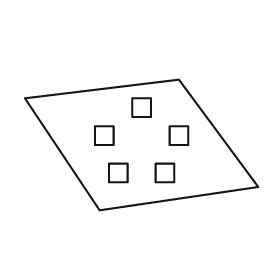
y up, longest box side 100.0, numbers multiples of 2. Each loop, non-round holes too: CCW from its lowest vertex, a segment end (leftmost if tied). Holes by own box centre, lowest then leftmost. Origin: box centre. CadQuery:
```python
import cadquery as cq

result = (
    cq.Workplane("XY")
    .moveTo(-18.0, -28.0)
    .lineTo(50.0, -18.0)
    .lineTo(16.0, 28.0)
    .lineTo(-50.0, 20.0)
    .close()
    .moveTo(-14.0, -16.0)
    .lineTo(-6.0, -16.0)
    .lineTo(-6.0, -8.0)
    .lineTo(-14.0, -8.0)
    .close()
    .moveTo(6.0, -16.0)
    .lineTo(14.0, -16.0)
    .lineTo(14.0, -8.0)
    .lineTo(6.0, -8.0)
    .close()
    .moveTo(-20.0, 0.0)
    .lineTo(-12.0, 0.0)
    .lineTo(-12.0, 8.0)
    .lineTo(-20.0, 8.0)
    .close()
    .moveTo(12.0, 0.0)
    .lineTo(20.0, 0.0)
    .lineTo(20.0, 8.0)
    .lineTo(12.0, 8.0)
    .close()
    .moveTo(-4.0, 12.0)
    .lineTo(4.0, 12.0)
    .lineTo(4.0, 20.0)
    .lineTo(-4.0, 20.0)
    .close()
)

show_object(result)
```